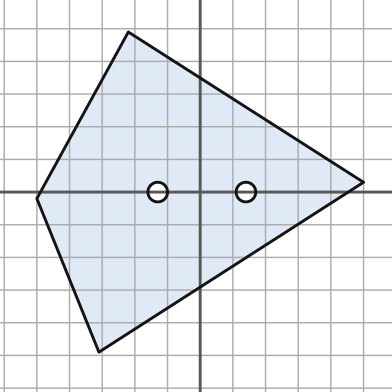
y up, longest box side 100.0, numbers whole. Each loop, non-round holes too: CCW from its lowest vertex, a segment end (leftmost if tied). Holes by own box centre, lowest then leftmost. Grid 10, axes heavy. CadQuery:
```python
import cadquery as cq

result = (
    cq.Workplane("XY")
    .moveTo(-31.0, -49.0)
    .lineTo(50.0, 3.0)
    .lineTo(-22.0, 49.0)
    .lineTo(-50.0, -2.0)
    .close()
    .moveTo(-13.0, 0.0)
    .circle(3.0)
    .moveTo(14.0, 0.0)
    .circle(3.0)
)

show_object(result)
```